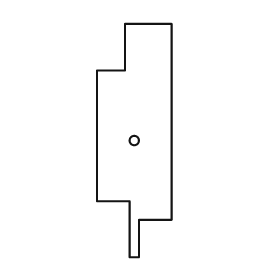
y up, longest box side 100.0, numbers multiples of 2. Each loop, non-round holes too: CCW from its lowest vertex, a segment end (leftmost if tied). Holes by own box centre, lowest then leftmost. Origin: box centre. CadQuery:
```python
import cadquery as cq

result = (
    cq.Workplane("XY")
    .moveTo(-2.0, -50.0)
    .lineTo(2.0, -50.0)
    .lineTo(2.0, -34.0)
    .lineTo(16.0, -34.0)
    .lineTo(16.0, 50.0)
    .lineTo(-4.0, 50.0)
    .lineTo(-4.0, 30.0)
    .lineTo(-16.0, 30.0)
    .lineTo(-16.0, -26.0)
    .lineTo(-2.0, -26.0)
    .close()
    .moveTo(0.0, 0.0)
    .circle(2.0)
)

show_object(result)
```